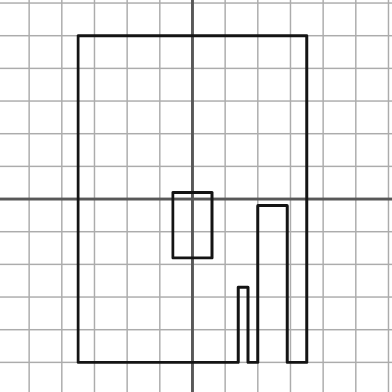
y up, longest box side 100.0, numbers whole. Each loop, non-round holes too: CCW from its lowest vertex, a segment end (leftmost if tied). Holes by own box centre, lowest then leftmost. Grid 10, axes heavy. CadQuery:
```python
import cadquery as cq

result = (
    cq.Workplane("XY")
    .moveTo(-35.0, -50.0)
    .lineTo(14.0, -50.0)
    .lineTo(14.0, -27.0)
    .lineTo(17.0, -27.0)
    .lineTo(17.0, -50.0)
    .lineTo(20.0, -50.0)
    .lineTo(20.0, -2.0)
    .lineTo(29.0, -2.0)
    .lineTo(29.0, -50.0)
    .lineTo(35.0, -50.0)
    .lineTo(35.0, 50.0)
    .lineTo(-35.0, 50.0)
    .close()
    .moveTo(-6.0, -18.0)
    .lineTo(6.0, -18.0)
    .lineTo(6.0, 2.0)
    .lineTo(-6.0, 2.0)
    .close()
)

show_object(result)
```